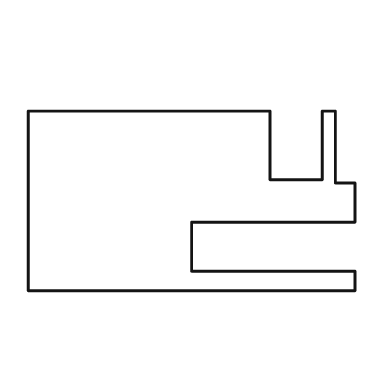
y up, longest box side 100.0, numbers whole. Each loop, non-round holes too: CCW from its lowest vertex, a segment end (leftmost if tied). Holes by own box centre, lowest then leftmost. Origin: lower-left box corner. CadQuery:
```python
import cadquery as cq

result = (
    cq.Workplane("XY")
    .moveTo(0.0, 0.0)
    .lineTo(100.0, 0.0)
    .lineTo(100.0, 6.0)
    .lineTo(50.0, 6.0)
    .lineTo(50.0, 21.0)
    .lineTo(100.0, 21.0)
    .lineTo(100.0, 33.0)
    .lineTo(94.0, 33.0)
    .lineTo(94.0, 55.0)
    .lineTo(90.0, 55.0)
    .lineTo(90.0, 34.0)
    .lineTo(74.0, 34.0)
    .lineTo(74.0, 55.0)
    .lineTo(0.0, 55.0)
    .close()
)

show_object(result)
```